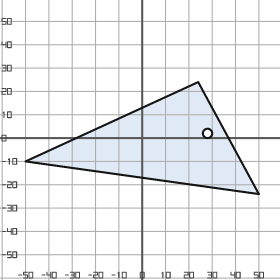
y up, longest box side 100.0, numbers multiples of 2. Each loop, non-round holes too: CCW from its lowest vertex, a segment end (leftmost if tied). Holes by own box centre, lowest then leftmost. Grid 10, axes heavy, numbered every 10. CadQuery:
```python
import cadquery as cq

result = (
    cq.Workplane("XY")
    .moveTo(50.0, -24.0)
    .lineTo(24.0, 24.0)
    .lineTo(-50.0, -10.0)
    .close()
    .moveTo(28.0, 2.0)
    .circle(2.0)
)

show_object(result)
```